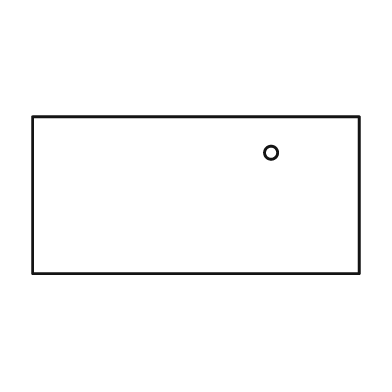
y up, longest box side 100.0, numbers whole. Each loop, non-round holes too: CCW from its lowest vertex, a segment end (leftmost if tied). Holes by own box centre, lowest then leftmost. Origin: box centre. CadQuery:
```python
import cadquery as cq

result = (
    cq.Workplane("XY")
    .moveTo(-50.0, -24.0)
    .lineTo(50.0, -24.0)
    .lineTo(50.0, 24.0)
    .lineTo(-50.0, 24.0)
    .close()
    .moveTo(23.0, 13.0)
    .circle(2.0)
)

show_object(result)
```